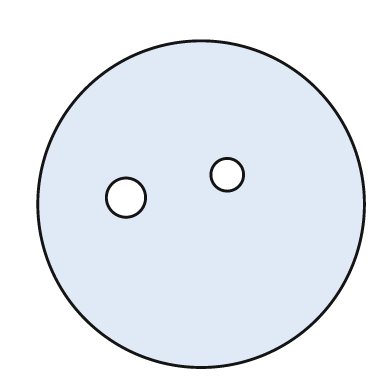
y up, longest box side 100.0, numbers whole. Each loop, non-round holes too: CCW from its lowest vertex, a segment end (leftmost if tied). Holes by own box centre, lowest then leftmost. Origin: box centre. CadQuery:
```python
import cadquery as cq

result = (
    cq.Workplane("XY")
    .moveTo(0.0, 0.0)
    .circle(50.0)
    .moveTo(-23.0, 2.0)
    .circle(6.0)
    .moveTo(8.0, 9.0)
    .circle(5.0)
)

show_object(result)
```